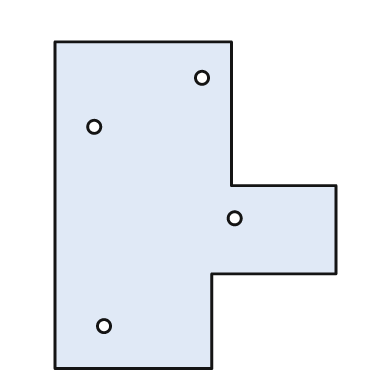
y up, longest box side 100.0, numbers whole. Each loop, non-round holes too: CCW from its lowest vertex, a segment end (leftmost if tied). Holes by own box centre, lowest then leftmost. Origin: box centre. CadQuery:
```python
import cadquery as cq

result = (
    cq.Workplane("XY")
    .moveTo(-43.0, -50.0)
    .lineTo(5.0, -50.0)
    .lineTo(5.0, -21.0)
    .lineTo(43.0, -21.0)
    .lineTo(43.0, 6.0)
    .lineTo(11.0, 6.0)
    .lineTo(11.0, 50.0)
    .lineTo(-43.0, 50.0)
    .close()
    .moveTo(-28.0, -37.0)
    .circle(2.0)
    .moveTo(12.0, -4.0)
    .circle(2.0)
    .moveTo(-31.0, 24.0)
    .circle(2.0)
    .moveTo(2.0, 39.0)
    .circle(2.0)
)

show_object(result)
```